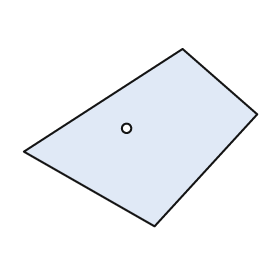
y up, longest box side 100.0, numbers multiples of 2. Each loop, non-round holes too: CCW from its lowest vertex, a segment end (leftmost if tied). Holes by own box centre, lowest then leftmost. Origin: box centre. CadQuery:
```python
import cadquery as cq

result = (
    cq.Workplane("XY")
    .moveTo(6.0, -38.0)
    .lineTo(50.0, 10.0)
    .lineTo(18.0, 38.0)
    .lineTo(-50.0, -6.0)
    .close()
    .moveTo(-6.0, 4.0)
    .circle(2.0)
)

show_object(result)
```